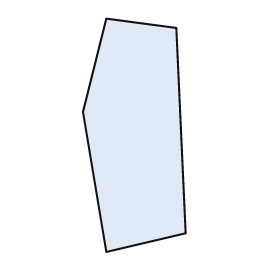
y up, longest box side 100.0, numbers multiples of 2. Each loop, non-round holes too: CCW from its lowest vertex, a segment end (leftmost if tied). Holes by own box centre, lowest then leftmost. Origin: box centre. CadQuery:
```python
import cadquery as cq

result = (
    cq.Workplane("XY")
    .moveTo(-12.0, -50.0)
    .lineTo(22.0, -42.0)
    .lineTo(18.0, 46.0)
    .lineTo(-12.0, 50.0)
    .lineTo(-22.0, 10.0)
    .close()
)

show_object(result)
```